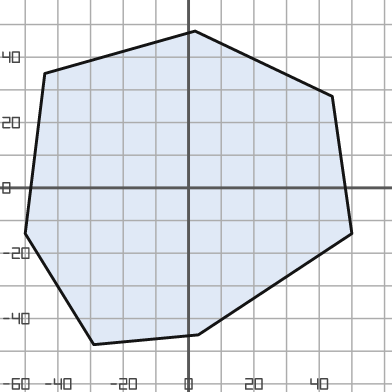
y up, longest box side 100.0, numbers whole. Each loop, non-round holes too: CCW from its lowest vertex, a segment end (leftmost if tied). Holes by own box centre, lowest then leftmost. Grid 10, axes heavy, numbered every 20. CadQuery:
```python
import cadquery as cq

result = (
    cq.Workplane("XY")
    .moveTo(-29.0, -48.0)
    .lineTo(3.0, -45.0)
    .lineTo(50.0, -14.0)
    .lineTo(44.0, 28.0)
    .lineTo(2.0, 48.0)
    .lineTo(-44.0, 35.0)
    .lineTo(-50.0, -14.0)
    .close()
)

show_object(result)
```